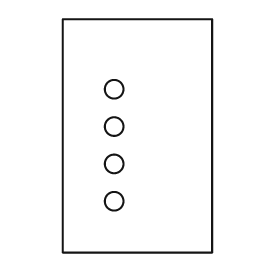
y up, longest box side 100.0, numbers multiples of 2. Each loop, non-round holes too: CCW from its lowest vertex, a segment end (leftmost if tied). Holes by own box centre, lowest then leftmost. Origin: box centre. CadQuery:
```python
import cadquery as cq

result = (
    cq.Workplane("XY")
    .moveTo(-32.0, -50.0)
    .lineTo(32.0, -50.0)
    .lineTo(32.0, 50.0)
    .lineTo(-32.0, 50.0)
    .close()
    .moveTo(-10.0, -28.0)
    .circle(4.0)
    .moveTo(-10.0, -12.0)
    .circle(4.0)
    .moveTo(-10.0, 4.0)
    .circle(4.0)
    .moveTo(-10.0, 20.0)
    .circle(4.0)
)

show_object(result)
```